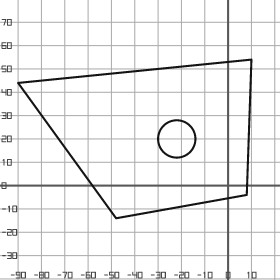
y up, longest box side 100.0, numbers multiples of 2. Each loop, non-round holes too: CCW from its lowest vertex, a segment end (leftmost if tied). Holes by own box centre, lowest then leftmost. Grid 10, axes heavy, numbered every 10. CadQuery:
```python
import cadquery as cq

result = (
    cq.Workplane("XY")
    .moveTo(-48.0, -14.0)
    .lineTo(8.0, -4.0)
    .lineTo(10.0, 54.0)
    .lineTo(-90.0, 44.0)
    .close()
    .moveTo(-22.0, 20.0)
    .circle(8.0)
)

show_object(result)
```